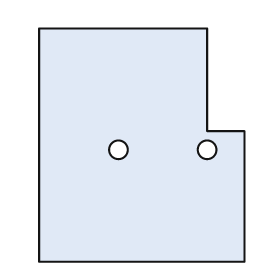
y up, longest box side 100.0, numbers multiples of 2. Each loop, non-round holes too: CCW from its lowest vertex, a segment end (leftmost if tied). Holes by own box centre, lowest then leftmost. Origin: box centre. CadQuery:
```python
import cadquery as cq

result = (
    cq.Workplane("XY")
    .moveTo(-44.0, -50.0)
    .lineTo(44.0, -50.0)
    .lineTo(44.0, 6.0)
    .lineTo(28.0, 6.0)
    .lineTo(28.0, 50.0)
    .lineTo(-44.0, 50.0)
    .close()
    .moveTo(-10.0, -2.0)
    .circle(4.0)
    .moveTo(28.0, -2.0)
    .circle(4.0)
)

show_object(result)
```